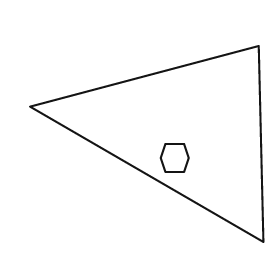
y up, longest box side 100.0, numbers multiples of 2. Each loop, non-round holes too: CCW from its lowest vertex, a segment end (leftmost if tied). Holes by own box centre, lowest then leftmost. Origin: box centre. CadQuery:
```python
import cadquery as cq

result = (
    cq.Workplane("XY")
    .moveTo(50.0, -42.0)
    .lineTo(48.0, 42.0)
    .lineTo(-50.0, 16.0)
    .close()
    .moveTo(8.0, -12.0)
    .lineTo(16.0, -12.0)
    .lineTo(18.0, -6.0)
    .lineTo(16.0, 0.0)
    .lineTo(8.0, 0.0)
    .lineTo(6.0, -6.0)
    .close()
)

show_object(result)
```